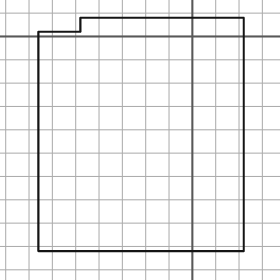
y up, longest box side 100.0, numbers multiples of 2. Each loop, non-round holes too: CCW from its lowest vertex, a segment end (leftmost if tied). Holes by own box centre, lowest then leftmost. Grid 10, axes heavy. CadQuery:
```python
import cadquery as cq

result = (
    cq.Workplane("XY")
    .moveTo(-66.0, -92.0)
    .lineTo(22.0, -92.0)
    .lineTo(22.0, 8.0)
    .lineTo(-48.0, 8.0)
    .lineTo(-48.0, 2.0)
    .lineTo(-66.0, 2.0)
    .close()
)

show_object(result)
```